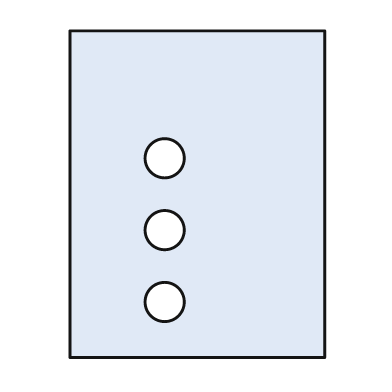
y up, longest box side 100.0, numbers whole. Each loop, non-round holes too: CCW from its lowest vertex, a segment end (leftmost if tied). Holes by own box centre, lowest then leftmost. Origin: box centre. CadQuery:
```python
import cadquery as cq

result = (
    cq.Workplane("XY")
    .moveTo(-39.0, -50.0)
    .lineTo(39.0, -50.0)
    .lineTo(39.0, 50.0)
    .lineTo(-39.0, 50.0)
    .close()
    .moveTo(-10.0, -33.0)
    .circle(6.0)
    .moveTo(-10.0, -11.0)
    .circle(6.0)
    .moveTo(-10.0, 11.0)
    .circle(6.0)
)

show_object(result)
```